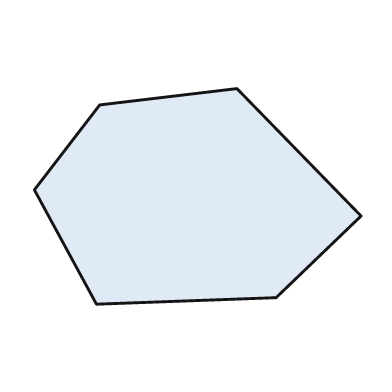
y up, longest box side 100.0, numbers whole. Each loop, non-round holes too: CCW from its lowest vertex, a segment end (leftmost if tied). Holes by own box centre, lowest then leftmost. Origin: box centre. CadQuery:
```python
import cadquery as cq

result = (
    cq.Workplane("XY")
    .moveTo(-31.0, -33.0)
    .lineTo(24.0, -31.0)
    .lineTo(50.0, -6.0)
    .lineTo(12.0, 33.0)
    .lineTo(-30.0, 28.0)
    .lineTo(-50.0, 2.0)
    .close()
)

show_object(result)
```